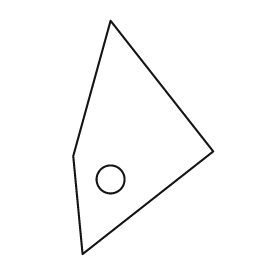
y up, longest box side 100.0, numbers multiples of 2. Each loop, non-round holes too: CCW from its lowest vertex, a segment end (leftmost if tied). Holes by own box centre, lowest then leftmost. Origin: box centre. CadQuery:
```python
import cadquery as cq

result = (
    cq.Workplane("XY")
    .moveTo(-26.0, -50.0)
    .lineTo(30.0, -6.0)
    .lineTo(-14.0, 50.0)
    .lineTo(-30.0, -8.0)
    .close()
    .moveTo(-14.0, -18.0)
    .circle(6.0)
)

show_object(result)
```